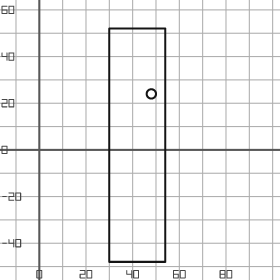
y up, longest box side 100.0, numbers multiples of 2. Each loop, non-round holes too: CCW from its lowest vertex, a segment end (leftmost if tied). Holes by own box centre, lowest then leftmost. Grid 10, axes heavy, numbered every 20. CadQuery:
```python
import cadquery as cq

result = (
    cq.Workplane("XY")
    .moveTo(30.0, -48.0)
    .lineTo(54.0, -48.0)
    .lineTo(54.0, 52.0)
    .lineTo(30.0, 52.0)
    .close()
    .moveTo(48.0, 24.0)
    .circle(2.0)
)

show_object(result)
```